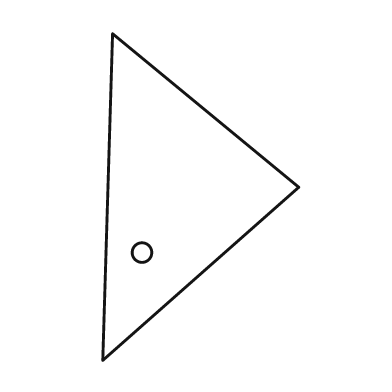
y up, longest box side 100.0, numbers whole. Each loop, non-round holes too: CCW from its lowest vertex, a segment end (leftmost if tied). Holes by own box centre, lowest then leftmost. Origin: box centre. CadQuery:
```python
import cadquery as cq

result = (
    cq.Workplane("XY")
    .moveTo(-30.0, -50.0)
    .lineTo(30.0, 3.0)
    .lineTo(-27.0, 50.0)
    .close()
    .moveTo(-18.0, -17.0)
    .circle(3.0)
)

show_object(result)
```